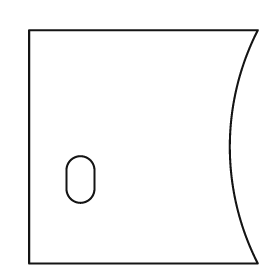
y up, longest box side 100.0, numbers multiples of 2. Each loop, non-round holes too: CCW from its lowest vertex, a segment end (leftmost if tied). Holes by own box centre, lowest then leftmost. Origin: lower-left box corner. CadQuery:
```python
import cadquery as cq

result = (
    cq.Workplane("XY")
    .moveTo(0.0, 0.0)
    .lineTo(98.0, 0.0)
    .threePointArc((86.0, 50.0), (98.0, 100.0))
    .lineTo(0.0, 100.0)
    .close()
    .moveTo(16.0, 32.0)
    .threePointArc((22.0, 26.0), (28.0, 32.0))
    .lineTo(28.0, 40.0)
    .threePointArc((22.0, 46.0), (16.0, 40.0))
    .close()
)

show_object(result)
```